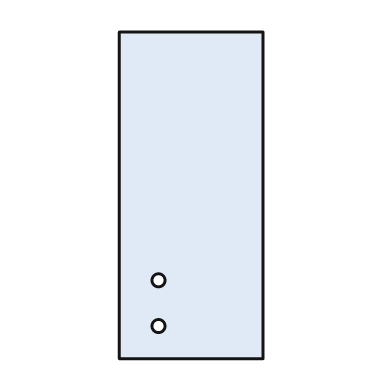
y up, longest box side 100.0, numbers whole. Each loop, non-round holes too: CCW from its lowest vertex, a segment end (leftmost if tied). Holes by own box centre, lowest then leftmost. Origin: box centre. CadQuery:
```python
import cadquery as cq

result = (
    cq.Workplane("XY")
    .moveTo(-22.0, -50.0)
    .lineTo(22.0, -50.0)
    .lineTo(22.0, 50.0)
    .lineTo(-22.0, 50.0)
    .close()
    .moveTo(-10.0, -40.0)
    .circle(2.0)
    .moveTo(-10.0, -26.0)
    .circle(2.0)
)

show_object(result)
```